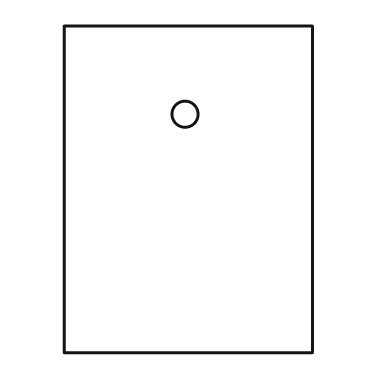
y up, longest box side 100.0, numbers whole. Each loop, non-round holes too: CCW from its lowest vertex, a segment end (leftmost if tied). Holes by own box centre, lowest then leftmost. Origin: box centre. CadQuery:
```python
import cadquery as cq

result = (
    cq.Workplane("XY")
    .moveTo(-38.0, -50.0)
    .lineTo(38.0, -50.0)
    .lineTo(38.0, 50.0)
    .lineTo(-38.0, 50.0)
    .close()
    .moveTo(-1.0, 23.0)
    .circle(4.0)
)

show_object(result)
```